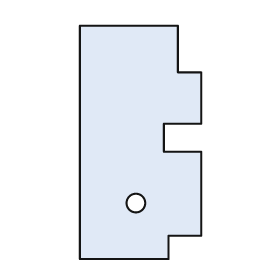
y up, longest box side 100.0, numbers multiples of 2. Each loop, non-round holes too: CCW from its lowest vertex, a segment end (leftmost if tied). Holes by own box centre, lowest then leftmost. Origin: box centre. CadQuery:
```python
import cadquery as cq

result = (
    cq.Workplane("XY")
    .moveTo(-26.0, -50.0)
    .lineTo(12.0, -50.0)
    .lineTo(12.0, -40.0)
    .lineTo(26.0, -40.0)
    .lineTo(26.0, -4.0)
    .lineTo(10.0, -4.0)
    .lineTo(10.0, 8.0)
    .lineTo(26.0, 8.0)
    .lineTo(26.0, 30.0)
    .lineTo(16.0, 30.0)
    .lineTo(16.0, 50.0)
    .lineTo(-26.0, 50.0)
    .close()
    .moveTo(-2.0, -26.0)
    .circle(4.0)
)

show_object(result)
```